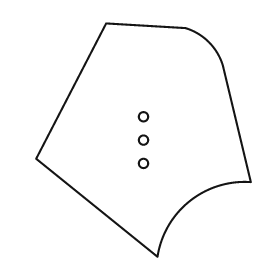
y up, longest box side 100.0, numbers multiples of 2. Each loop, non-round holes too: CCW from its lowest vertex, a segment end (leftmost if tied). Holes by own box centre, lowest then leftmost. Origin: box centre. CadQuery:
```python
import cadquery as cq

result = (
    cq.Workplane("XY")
    .moveTo(6.0, -50.0)
    .threePointArc((20.0, -26.0), (46.0, -18.0))
    .lineTo(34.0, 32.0)
    .threePointArc((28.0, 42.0), (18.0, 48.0))
    .lineTo(-16.0, 50.0)
    .lineTo(-46.0, -8.0)
    .close()
    .moveTo(0.0, -10.0)
    .circle(2.0)
    .moveTo(0.0, 0.0)
    .circle(2.0)
    .moveTo(0.0, 10.0)
    .circle(2.0)
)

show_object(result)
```